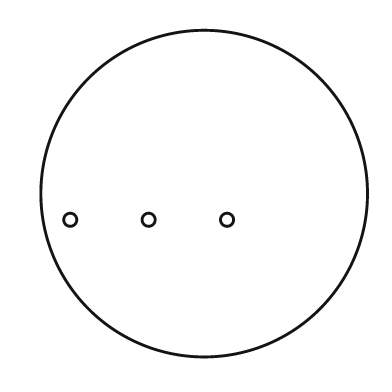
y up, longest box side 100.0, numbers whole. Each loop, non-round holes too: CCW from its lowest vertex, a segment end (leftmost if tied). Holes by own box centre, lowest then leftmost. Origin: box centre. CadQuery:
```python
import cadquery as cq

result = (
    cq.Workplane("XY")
    .moveTo(0.0, 0.0)
    .circle(50.0)
    .moveTo(-41.0, -8.0)
    .circle(2.0)
    .moveTo(-17.0, -8.0)
    .circle(2.0)
    .moveTo(7.0, -8.0)
    .circle(2.0)
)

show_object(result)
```